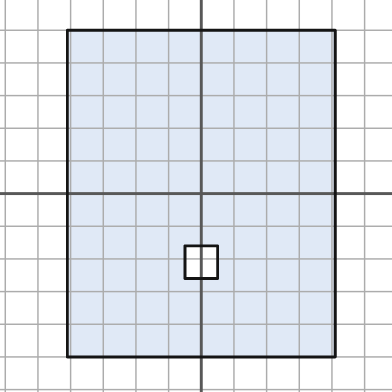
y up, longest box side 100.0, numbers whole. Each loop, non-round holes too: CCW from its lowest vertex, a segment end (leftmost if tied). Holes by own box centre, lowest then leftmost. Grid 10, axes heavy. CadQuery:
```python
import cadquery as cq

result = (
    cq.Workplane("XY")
    .moveTo(-41.0, -50.0)
    .lineTo(41.0, -50.0)
    .lineTo(41.0, 50.0)
    .lineTo(-41.0, 50.0)
    .close()
    .moveTo(-5.0, -26.0)
    .lineTo(5.0, -26.0)
    .lineTo(5.0, -16.0)
    .lineTo(-5.0, -16.0)
    .close()
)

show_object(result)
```